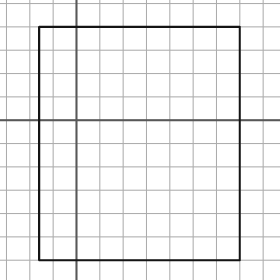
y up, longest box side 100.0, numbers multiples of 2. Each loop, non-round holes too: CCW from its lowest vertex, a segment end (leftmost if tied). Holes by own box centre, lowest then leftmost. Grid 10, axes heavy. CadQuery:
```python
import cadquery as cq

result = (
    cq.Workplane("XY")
    .moveTo(-16.0, -60.0)
    .lineTo(70.0, -60.0)
    .lineTo(70.0, 40.0)
    .lineTo(-16.0, 40.0)
    .close()
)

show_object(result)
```